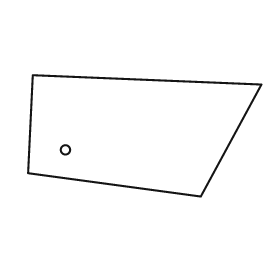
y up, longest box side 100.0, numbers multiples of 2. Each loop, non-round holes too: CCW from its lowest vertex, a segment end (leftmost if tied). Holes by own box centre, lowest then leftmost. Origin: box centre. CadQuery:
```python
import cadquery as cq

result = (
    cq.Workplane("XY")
    .moveTo(24.0, -26.0)
    .lineTo(50.0, 22.0)
    .lineTo(-48.0, 26.0)
    .lineTo(-50.0, -16.0)
    .close()
    .moveTo(-34.0, -6.0)
    .circle(2.0)
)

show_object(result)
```